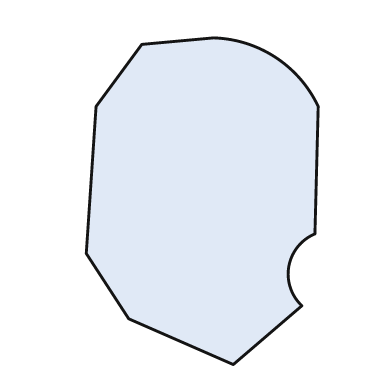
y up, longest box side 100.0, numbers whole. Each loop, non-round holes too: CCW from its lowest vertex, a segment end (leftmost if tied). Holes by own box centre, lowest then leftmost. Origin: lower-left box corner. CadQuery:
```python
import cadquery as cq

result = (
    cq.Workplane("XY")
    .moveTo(45.0, 0.0)
    .lineTo(66.0, 18.0)
    .threePointArc((62.0, 30.0), (70.0, 40.0))
    .lineTo(71.0, 79.0)
    .threePointArc((58.0, 94.0), (39.0, 100.0))
    .lineTo(17.0, 98.0)
    .lineTo(3.0, 79.0)
    .lineTo(0.0, 34.0)
    .lineTo(13.0, 14.0)
    .close()
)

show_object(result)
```